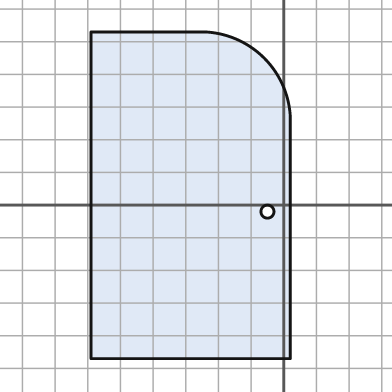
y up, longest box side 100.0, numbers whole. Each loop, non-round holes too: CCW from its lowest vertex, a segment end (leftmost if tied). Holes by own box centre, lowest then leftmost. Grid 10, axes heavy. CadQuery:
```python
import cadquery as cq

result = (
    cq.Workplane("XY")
    .moveTo(-59.0, -47.0)
    .lineTo(2.0, -47.0)
    .lineTo(2.0, 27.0)
    .threePointArc((-6.0, 45.0), (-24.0, 53.0))
    .lineTo(-59.0, 53.0)
    .close()
    .moveTo(-5.0, -2.0)
    .circle(2.0)
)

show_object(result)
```